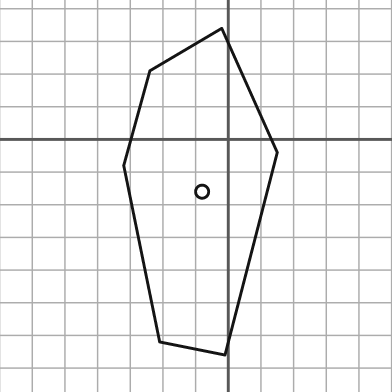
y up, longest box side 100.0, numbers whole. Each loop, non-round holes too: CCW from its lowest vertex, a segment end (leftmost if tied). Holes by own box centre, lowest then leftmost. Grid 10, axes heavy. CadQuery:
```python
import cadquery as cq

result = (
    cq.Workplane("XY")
    .moveTo(-1.0, -66.0)
    .lineTo(15.0, -4.0)
    .lineTo(-2.0, 34.0)
    .lineTo(-24.0, 21.0)
    .lineTo(-32.0, -8.0)
    .lineTo(-21.0, -62.0)
    .close()
    .moveTo(-8.0, -16.0)
    .circle(2.0)
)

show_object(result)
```